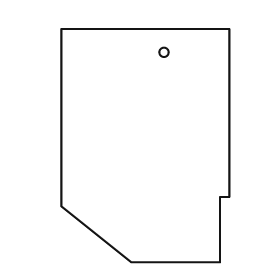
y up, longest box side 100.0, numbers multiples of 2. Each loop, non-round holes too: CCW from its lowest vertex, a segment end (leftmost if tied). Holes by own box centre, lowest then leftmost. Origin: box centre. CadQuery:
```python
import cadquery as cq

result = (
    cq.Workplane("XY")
    .moveTo(-6.0, -50.0)
    .lineTo(32.0, -50.0)
    .lineTo(32.0, -22.0)
    .lineTo(36.0, -22.0)
    .lineTo(36.0, 50.0)
    .lineTo(-36.0, 50.0)
    .lineTo(-36.0, -26.0)
    .close()
    .moveTo(8.0, 40.0)
    .circle(2.0)
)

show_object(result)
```